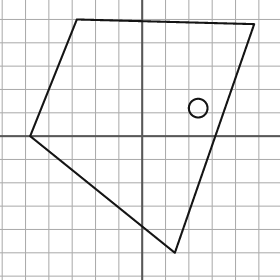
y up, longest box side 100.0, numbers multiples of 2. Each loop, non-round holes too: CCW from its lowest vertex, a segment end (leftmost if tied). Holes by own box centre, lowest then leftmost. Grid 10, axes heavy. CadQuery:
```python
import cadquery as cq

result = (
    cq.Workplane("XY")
    .moveTo(14.0, -50.0)
    .lineTo(48.0, 48.0)
    .lineTo(-28.0, 50.0)
    .lineTo(-48.0, 0.0)
    .close()
    .moveTo(24.0, 12.0)
    .circle(4.0)
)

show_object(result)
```